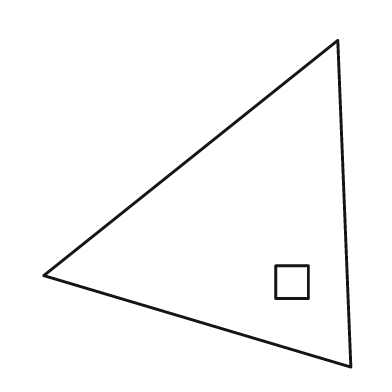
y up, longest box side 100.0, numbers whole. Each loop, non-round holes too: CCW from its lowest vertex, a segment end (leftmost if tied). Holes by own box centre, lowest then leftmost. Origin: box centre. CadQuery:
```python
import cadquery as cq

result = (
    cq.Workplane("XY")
    .moveTo(47.0, -50.0)
    .lineTo(43.0, 50.0)
    .lineTo(-47.0, -22.0)
    .close()
    .moveTo(24.0, -29.0)
    .lineTo(34.0, -29.0)
    .lineTo(34.0, -19.0)
    .lineTo(24.0, -19.0)
    .close()
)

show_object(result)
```